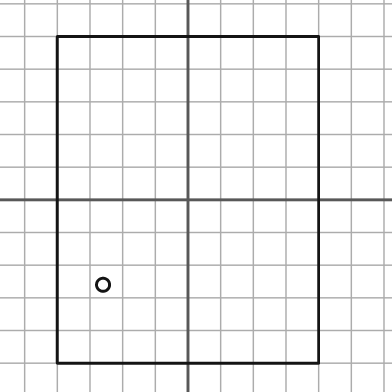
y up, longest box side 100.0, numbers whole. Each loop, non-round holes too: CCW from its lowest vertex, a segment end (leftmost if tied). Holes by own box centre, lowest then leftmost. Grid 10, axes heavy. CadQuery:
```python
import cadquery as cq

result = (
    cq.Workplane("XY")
    .moveTo(-40.0, -50.0)
    .lineTo(40.0, -50.0)
    .lineTo(40.0, 50.0)
    .lineTo(-40.0, 50.0)
    .close()
    .moveTo(-26.0, -26.0)
    .circle(2.0)
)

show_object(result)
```